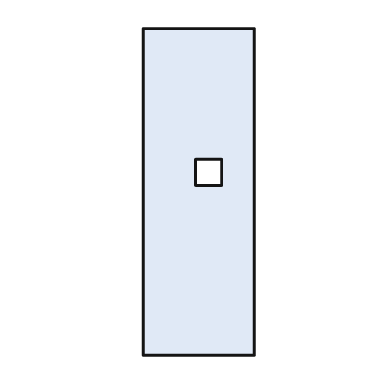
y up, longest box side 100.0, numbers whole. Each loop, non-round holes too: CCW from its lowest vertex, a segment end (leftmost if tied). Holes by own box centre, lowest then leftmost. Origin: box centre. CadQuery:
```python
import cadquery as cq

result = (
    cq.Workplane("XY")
    .moveTo(-17.0, -50.0)
    .lineTo(17.0, -50.0)
    .lineTo(17.0, 50.0)
    .lineTo(-17.0, 50.0)
    .close()
    .moveTo(-1.0, 2.0)
    .lineTo(7.0, 2.0)
    .lineTo(7.0, 10.0)
    .lineTo(-1.0, 10.0)
    .close()
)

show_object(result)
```